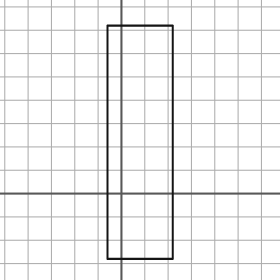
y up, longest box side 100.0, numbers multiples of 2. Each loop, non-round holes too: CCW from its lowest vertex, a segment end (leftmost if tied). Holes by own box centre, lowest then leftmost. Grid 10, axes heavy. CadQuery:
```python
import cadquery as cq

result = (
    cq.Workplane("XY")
    .moveTo(-6.0, -28.0)
    .lineTo(22.0, -28.0)
    .lineTo(22.0, 72.0)
    .lineTo(-6.0, 72.0)
    .close()
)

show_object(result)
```